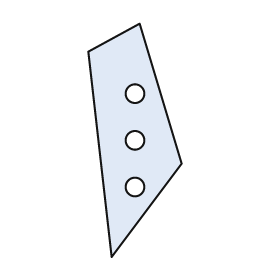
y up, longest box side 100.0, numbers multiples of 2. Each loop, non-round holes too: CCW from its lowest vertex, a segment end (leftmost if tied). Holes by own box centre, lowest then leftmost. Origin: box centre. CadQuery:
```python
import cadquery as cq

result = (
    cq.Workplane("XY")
    .moveTo(-10.0, -50.0)
    .lineTo(20.0, -10.0)
    .lineTo(2.0, 50.0)
    .lineTo(-20.0, 38.0)
    .close()
    .moveTo(0.0, -20.0)
    .circle(4.0)
    .moveTo(0.0, 0.0)
    .circle(4.0)
    .moveTo(0.0, 20.0)
    .circle(4.0)
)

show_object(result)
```